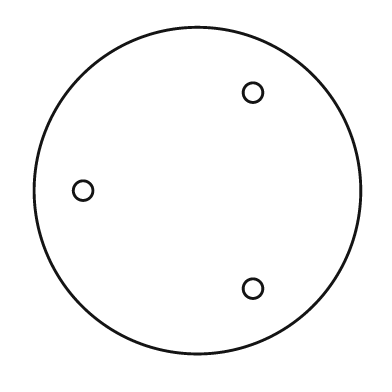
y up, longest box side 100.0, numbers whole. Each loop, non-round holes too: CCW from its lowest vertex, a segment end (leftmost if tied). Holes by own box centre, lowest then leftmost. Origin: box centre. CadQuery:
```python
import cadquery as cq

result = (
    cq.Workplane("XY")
    .moveTo(0.0, 0.0)
    .circle(50.0)
    .moveTo(17.0, -30.0)
    .circle(3.0)
    .moveTo(-35.0, 0.0)
    .circle(3.0)
    .moveTo(17.0, 30.0)
    .circle(3.0)
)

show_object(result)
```